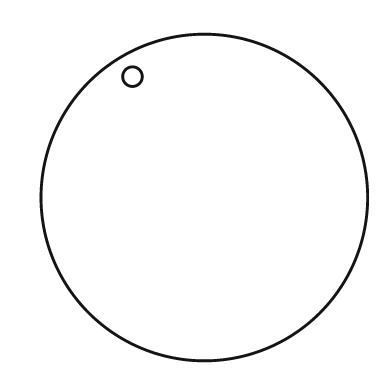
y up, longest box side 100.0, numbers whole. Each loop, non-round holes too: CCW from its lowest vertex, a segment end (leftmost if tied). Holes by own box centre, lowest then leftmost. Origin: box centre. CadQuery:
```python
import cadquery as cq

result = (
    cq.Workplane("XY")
    .moveTo(0.0, 0.0)
    .circle(50.0)
    .moveTo(-22.0, 37.0)
    .circle(3.0)
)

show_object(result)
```